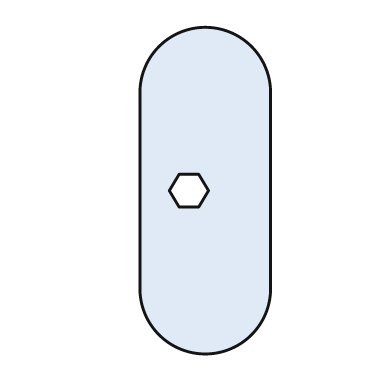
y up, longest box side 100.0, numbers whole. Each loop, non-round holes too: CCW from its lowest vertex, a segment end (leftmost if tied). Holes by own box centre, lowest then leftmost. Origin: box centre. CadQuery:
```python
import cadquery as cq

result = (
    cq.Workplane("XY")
    .moveTo(-20.0, -30.0)
    .threePointArc((0.0, -50.0), (20.0, -30.0))
    .lineTo(20.0, 30.0)
    .threePointArc((0.0, 50.0), (-20.0, 30.0))
    .close()
    .moveTo(-8.0, -5.0)
    .lineTo(-2.0, -5.0)
    .lineTo(1.0, 0.0)
    .lineTo(-2.0, 5.0)
    .lineTo(-8.0, 5.0)
    .lineTo(-11.0, 0.0)
    .close()
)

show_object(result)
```